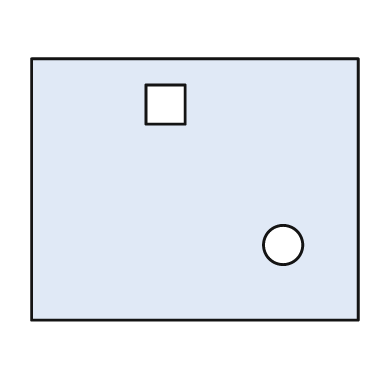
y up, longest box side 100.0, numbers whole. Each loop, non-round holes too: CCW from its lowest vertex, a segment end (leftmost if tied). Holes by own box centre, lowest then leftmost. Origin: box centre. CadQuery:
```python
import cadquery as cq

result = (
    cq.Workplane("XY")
    .moveTo(-50.0, -40.0)
    .lineTo(50.0, -40.0)
    .lineTo(50.0, 40.0)
    .lineTo(-50.0, 40.0)
    .close()
    .moveTo(27.0, -17.0)
    .circle(6.0)
    .moveTo(-15.0, 20.0)
    .lineTo(-3.0, 20.0)
    .lineTo(-3.0, 32.0)
    .lineTo(-15.0, 32.0)
    .close()
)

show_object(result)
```